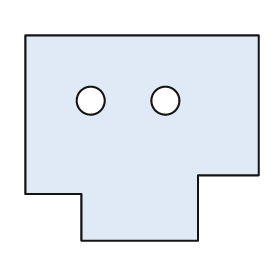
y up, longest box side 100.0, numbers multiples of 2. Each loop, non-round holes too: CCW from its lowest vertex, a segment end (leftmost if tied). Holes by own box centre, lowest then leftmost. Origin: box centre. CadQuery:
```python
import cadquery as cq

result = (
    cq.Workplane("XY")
    .moveTo(-26.0, -44.0)
    .lineTo(24.0, -44.0)
    .lineTo(24.0, -16.0)
    .lineTo(50.0, -16.0)
    .lineTo(50.0, 44.0)
    .lineTo(-50.0, 44.0)
    .lineTo(-50.0, -24.0)
    .lineTo(-26.0, -24.0)
    .close()
    .moveTo(-22.0, 16.0)
    .circle(6.0)
    .moveTo(10.0, 16.0)
    .circle(6.0)
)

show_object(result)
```